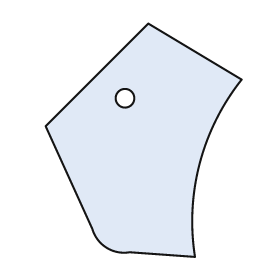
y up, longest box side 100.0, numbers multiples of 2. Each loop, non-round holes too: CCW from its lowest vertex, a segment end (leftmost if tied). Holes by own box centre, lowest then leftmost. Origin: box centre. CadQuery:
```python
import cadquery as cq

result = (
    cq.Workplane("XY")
    .moveTo(22.0, -50.0)
    .threePointArc((24.0, -10.0), (42.0, 26.0))
    .lineTo(2.0, 50.0)
    .lineTo(-42.0, 6.0)
    .lineTo(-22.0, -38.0)
    .threePointArc((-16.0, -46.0), (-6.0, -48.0))
    .close()
    .moveTo(-8.0, 18.0)
    .circle(4.0)
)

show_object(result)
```